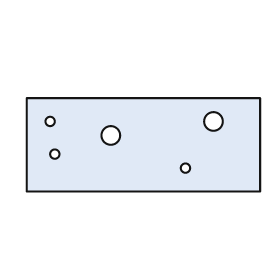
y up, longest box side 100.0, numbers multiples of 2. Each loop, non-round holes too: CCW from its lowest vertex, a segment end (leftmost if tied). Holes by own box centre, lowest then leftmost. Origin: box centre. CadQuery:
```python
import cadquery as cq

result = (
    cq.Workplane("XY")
    .moveTo(-50.0, -20.0)
    .lineTo(50.0, -20.0)
    .lineTo(50.0, 20.0)
    .lineTo(-50.0, 20.0)
    .close()
    .moveTo(18.0, -10.0)
    .circle(2.0)
    .moveTo(-38.0, -4.0)
    .circle(2.0)
    .moveTo(-14.0, 4.0)
    .circle(4.0)
    .moveTo(-40.0, 10.0)
    .circle(2.0)
    .moveTo(30.0, 10.0)
    .circle(4.0)
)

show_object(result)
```